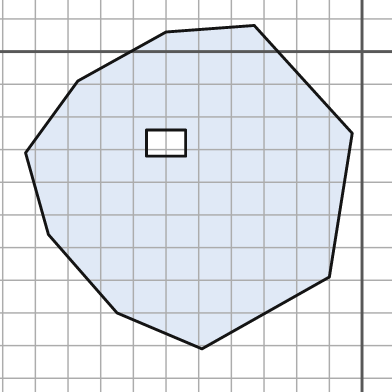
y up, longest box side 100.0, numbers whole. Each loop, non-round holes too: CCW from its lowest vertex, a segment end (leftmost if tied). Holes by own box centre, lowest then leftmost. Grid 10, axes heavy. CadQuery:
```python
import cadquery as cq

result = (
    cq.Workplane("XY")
    .moveTo(-49.0, -91.0)
    .lineTo(-10.0, -69.0)
    .lineTo(-3.0, -25.0)
    .lineTo(-33.0, 8.0)
    .lineTo(-60.0, 6.0)
    .lineTo(-87.0, -9.0)
    .lineTo(-103.0, -31.0)
    .lineTo(-96.0, -56.0)
    .lineTo(-75.0, -80.0)
    .close()
    .moveTo(-66.0, -32.0)
    .lineTo(-54.0, -32.0)
    .lineTo(-54.0, -24.0)
    .lineTo(-66.0, -24.0)
    .close()
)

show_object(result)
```